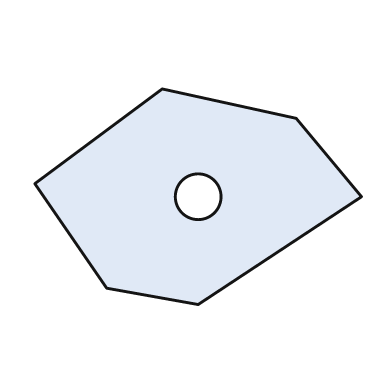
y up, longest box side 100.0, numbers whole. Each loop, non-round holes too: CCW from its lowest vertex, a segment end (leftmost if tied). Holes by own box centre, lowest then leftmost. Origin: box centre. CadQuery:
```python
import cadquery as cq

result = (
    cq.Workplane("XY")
    .moveTo(0.0, -33.0)
    .lineTo(50.0, 0.0)
    .lineTo(30.0, 24.0)
    .lineTo(-11.0, 33.0)
    .lineTo(-50.0, 4.0)
    .lineTo(-28.0, -28.0)
    .close()
    .moveTo(0.0, 0.0)
    .circle(7.0)
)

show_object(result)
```